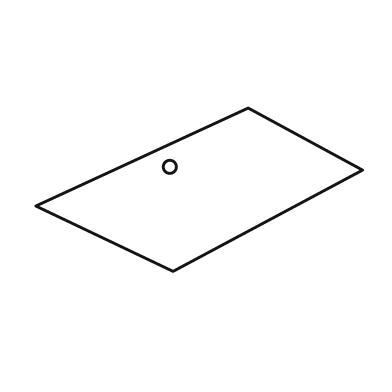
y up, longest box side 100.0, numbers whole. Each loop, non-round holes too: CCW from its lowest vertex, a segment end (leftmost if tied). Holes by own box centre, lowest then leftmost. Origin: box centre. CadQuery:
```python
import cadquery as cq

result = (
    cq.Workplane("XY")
    .moveTo(-8.0, -25.0)
    .lineTo(50.0, 6.0)
    .lineTo(15.0, 25.0)
    .lineTo(-50.0, -5.0)
    .close()
    .moveTo(-9.0, 7.0)
    .circle(2.0)
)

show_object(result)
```